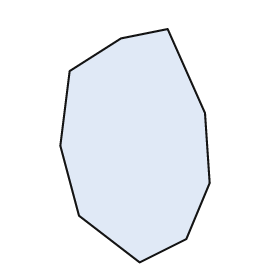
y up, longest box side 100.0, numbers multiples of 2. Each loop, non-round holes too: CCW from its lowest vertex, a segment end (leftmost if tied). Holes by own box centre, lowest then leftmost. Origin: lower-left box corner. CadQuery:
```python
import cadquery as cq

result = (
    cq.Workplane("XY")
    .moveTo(34.0, 0.0)
    .lineTo(54.0, 10.0)
    .lineTo(64.0, 34.0)
    .lineTo(62.0, 64.0)
    .lineTo(46.0, 100.0)
    .lineTo(26.0, 96.0)
    .lineTo(4.0, 82.0)
    .lineTo(0.0, 50.0)
    .lineTo(8.0, 20.0)
    .close()
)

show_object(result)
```